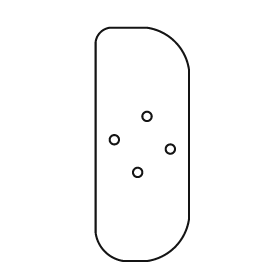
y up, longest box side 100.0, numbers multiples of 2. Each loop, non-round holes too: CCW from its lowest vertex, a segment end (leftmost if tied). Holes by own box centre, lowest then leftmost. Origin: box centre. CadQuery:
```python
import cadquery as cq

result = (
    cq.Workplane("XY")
    .moveTo(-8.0, -50.0)
    .lineTo(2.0, -50.0)
    .threePointArc((14.0, -44.0), (20.0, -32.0))
    .lineTo(20.0, 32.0)
    .threePointArc((14.0, 44.0), (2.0, 50.0))
    .lineTo(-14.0, 50.0)
    .threePointArc((-18.0, 48.0), (-20.0, 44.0))
    .lineTo(-20.0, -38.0)
    .threePointArc((-16.0, -46.0), (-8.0, -50.0))
    .close()
    .moveTo(-2.0, -12.0)
    .circle(2.0)
    .moveTo(12.0, -2.0)
    .circle(2.0)
    .moveTo(-12.0, 2.0)
    .circle(2.0)
    .moveTo(2.0, 12.0)
    .circle(2.0)
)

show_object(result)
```